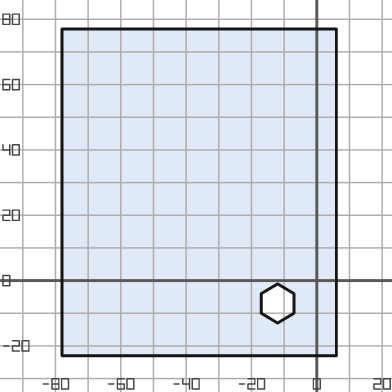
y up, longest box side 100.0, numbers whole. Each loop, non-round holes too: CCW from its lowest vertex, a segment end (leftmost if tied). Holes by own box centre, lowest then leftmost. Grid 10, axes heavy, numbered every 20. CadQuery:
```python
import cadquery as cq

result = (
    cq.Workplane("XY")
    .moveTo(-78.0, -23.0)
    .lineTo(6.0, -23.0)
    .lineTo(6.0, 77.0)
    .lineTo(-78.0, 77.0)
    .close()
    .moveTo(-12.0, -13.0)
    .lineTo(-7.0, -10.0)
    .lineTo(-7.0, -4.0)
    .lineTo(-12.0, -1.0)
    .lineTo(-17.0, -4.0)
    .lineTo(-17.0, -10.0)
    .close()
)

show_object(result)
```